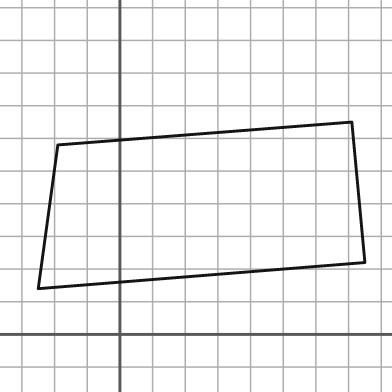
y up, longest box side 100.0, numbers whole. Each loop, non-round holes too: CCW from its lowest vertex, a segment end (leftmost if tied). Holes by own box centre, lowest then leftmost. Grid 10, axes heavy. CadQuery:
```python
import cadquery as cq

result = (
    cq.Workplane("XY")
    .moveTo(-25.0, 14.0)
    .lineTo(75.0, 22.0)
    .lineTo(71.0, 65.0)
    .lineTo(-19.0, 58.0)
    .close()
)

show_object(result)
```